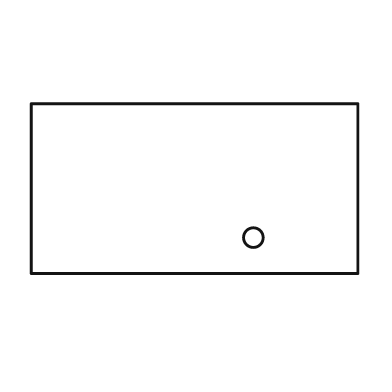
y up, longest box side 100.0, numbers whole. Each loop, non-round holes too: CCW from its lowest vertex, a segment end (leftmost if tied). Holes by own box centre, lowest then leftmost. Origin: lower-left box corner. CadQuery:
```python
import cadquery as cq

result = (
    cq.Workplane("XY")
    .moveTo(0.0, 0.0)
    .lineTo(100.0, 0.0)
    .lineTo(100.0, 52.0)
    .lineTo(0.0, 52.0)
    .close()
    .moveTo(68.0, 11.0)
    .circle(3.0)
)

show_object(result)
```